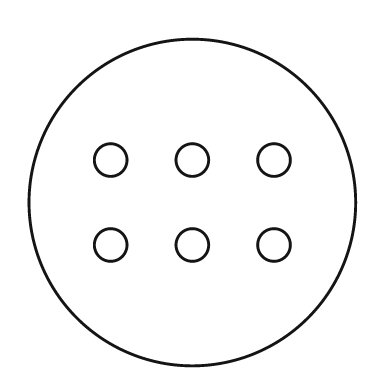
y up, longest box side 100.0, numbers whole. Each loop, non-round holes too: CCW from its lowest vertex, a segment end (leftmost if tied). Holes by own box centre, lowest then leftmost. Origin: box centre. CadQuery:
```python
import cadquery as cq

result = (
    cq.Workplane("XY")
    .moveTo(0.0, 0.0)
    .circle(50.0)
    .moveTo(-25.0, -13.0)
    .circle(5.0)
    .moveTo(0.0, -13.0)
    .circle(5.0)
    .moveTo(25.0, -13.0)
    .circle(5.0)
    .moveTo(-25.0, 13.0)
    .circle(5.0)
    .moveTo(0.0, 13.0)
    .circle(5.0)
    .moveTo(25.0, 13.0)
    .circle(5.0)
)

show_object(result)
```